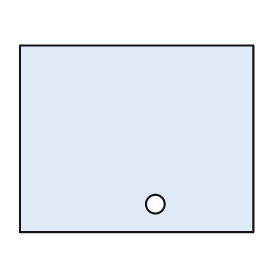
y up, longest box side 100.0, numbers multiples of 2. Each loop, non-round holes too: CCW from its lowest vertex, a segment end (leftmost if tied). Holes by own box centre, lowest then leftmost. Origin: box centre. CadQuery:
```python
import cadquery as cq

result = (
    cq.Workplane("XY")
    .moveTo(-50.0, -40.0)
    .lineTo(50.0, -40.0)
    .lineTo(50.0, 40.0)
    .lineTo(-50.0, 40.0)
    .close()
    .moveTo(8.0, -28.0)
    .circle(4.0)
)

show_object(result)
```